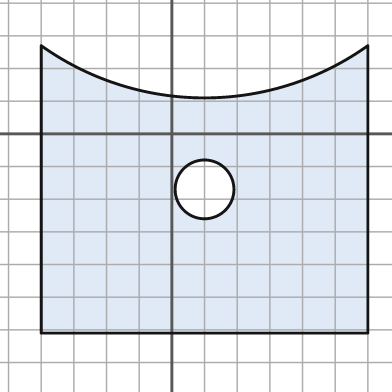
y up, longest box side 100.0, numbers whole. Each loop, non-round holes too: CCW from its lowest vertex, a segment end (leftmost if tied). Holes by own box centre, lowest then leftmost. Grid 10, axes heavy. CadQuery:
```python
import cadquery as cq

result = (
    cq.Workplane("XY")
    .moveTo(-40.0, -61.0)
    .lineTo(60.0, -61.0)
    .lineTo(60.0, 27.0)
    .threePointArc((10.0, 11.0), (-40.0, 27.0))
    .close()
    .moveTo(10.0, -17.0)
    .circle(9.0)
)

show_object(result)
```